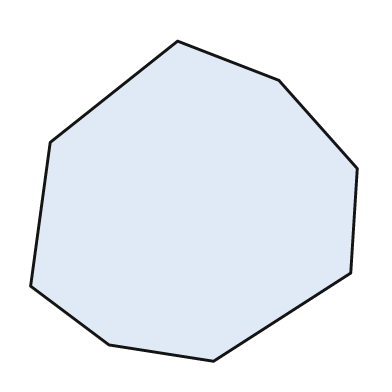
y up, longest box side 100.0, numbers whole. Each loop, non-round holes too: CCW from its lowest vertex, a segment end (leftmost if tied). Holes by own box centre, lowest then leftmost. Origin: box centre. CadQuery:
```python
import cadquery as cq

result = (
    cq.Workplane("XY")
    .moveTo(6.0, -49.0)
    .lineTo(48.0, -22.0)
    .lineTo(50.0, 10.0)
    .lineTo(26.0, 37.0)
    .lineTo(-5.0, 49.0)
    .lineTo(-44.0, 18.0)
    .lineTo(-50.0, -26.0)
    .lineTo(-26.0, -44.0)
    .close()
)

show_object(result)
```